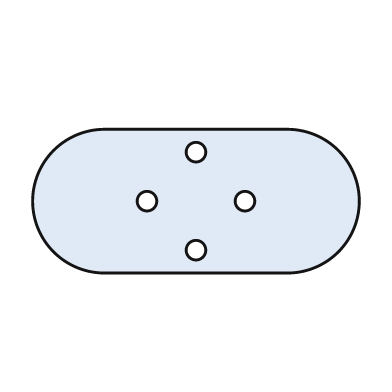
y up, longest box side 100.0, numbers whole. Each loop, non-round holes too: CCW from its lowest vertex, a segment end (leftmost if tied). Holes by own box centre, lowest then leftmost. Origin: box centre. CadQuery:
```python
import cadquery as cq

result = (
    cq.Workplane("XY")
    .moveTo(-28.0, -22.0)
    .lineTo(28.0, -22.0)
    .threePointArc((50.0, 0.0), (28.0, 22.0))
    .lineTo(-28.0, 22.0)
    .threePointArc((-50.0, 0.0), (-28.0, -22.0))
    .close()
    .moveTo(0.0, -15.0)
    .circle(3.0)
    .moveTo(-15.0, 0.0)
    .circle(3.0)
    .moveTo(15.0, 0.0)
    .circle(3.0)
    .moveTo(0.0, 15.0)
    .circle(3.0)
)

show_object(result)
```